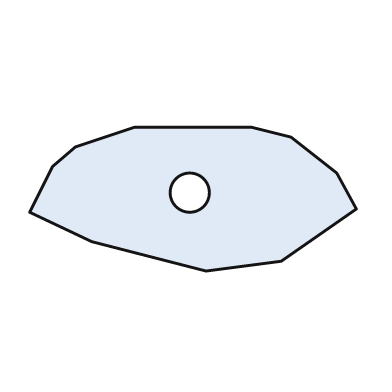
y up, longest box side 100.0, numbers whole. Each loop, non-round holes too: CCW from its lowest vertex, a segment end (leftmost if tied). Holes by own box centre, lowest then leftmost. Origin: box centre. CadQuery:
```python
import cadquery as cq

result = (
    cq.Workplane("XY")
    .moveTo(4.0, -22.0)
    .lineTo(27.0, -19.0)
    .lineTo(50.0, -3.0)
    .lineTo(44.0, 8.0)
    .lineTo(30.0, 19.0)
    .lineTo(18.0, 22.0)
    .lineTo(-18.0, 22.0)
    .lineTo(-36.0, 16.0)
    .lineTo(-43.0, 10.0)
    .lineTo(-50.0, -4.0)
    .lineTo(-31.0, -13.0)
    .close()
    .moveTo(-1.0, 2.0)
    .circle(6.0)
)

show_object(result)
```